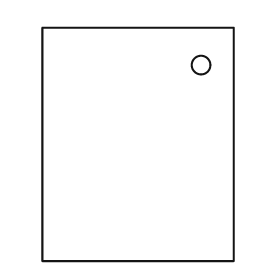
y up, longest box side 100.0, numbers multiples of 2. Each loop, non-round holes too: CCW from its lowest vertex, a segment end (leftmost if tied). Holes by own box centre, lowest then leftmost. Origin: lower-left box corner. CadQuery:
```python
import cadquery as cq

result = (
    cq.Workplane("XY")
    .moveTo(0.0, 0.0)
    .lineTo(82.0, 0.0)
    .lineTo(82.0, 100.0)
    .lineTo(0.0, 100.0)
    .close()
    .moveTo(68.0, 84.0)
    .circle(4.0)
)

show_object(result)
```